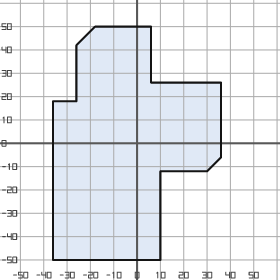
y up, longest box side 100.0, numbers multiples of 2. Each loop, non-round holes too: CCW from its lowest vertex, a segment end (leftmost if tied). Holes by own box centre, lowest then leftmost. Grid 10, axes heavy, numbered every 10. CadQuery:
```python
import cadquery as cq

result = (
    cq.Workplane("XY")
    .moveTo(-36.0, -50.0)
    .lineTo(10.0, -50.0)
    .lineTo(10.0, -12.0)
    .lineTo(30.0, -12.0)
    .lineTo(36.0, -6.0)
    .lineTo(36.0, 26.0)
    .lineTo(6.0, 26.0)
    .lineTo(6.0, 50.0)
    .lineTo(-18.0, 50.0)
    .lineTo(-26.0, 42.0)
    .lineTo(-26.0, 18.0)
    .lineTo(-36.0, 18.0)
    .close()
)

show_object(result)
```